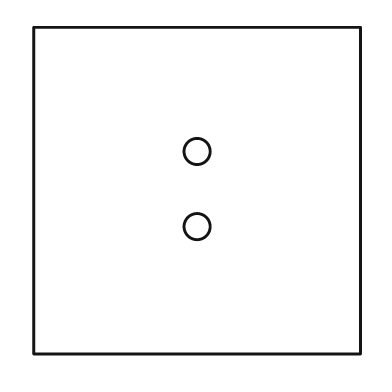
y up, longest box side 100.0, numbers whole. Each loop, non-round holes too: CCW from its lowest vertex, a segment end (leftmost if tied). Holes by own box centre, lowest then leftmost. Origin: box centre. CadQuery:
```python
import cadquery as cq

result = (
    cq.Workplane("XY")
    .moveTo(-50.0, -50.0)
    .lineTo(50.0, -50.0)
    .lineTo(50.0, 50.0)
    .lineTo(-50.0, 50.0)
    .close()
    .moveTo(0.0, -11.0)
    .circle(4.0)
    .moveTo(0.0, 12.0)
    .circle(4.0)
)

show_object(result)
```